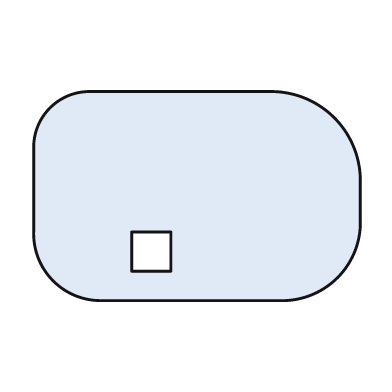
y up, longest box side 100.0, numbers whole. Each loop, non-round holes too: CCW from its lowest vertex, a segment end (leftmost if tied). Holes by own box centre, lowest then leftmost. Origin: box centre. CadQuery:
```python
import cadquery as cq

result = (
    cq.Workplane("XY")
    .moveTo(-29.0, -32.0)
    .lineTo(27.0, -32.0)
    .threePointArc((43.0, -25.0), (50.0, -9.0))
    .lineTo(50.0, 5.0)
    .threePointArc((42.0, 24.0), (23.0, 32.0))
    .lineTo(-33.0, 32.0)
    .threePointArc((-45.0, 27.0), (-50.0, 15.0))
    .lineTo(-50.0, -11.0)
    .threePointArc((-44.0, -26.0), (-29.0, -32.0))
    .close()
    .moveTo(-20.0, -23.0)
    .lineTo(-8.0, -23.0)
    .lineTo(-8.0, -11.0)
    .lineTo(-20.0, -11.0)
    .close()
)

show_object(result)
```